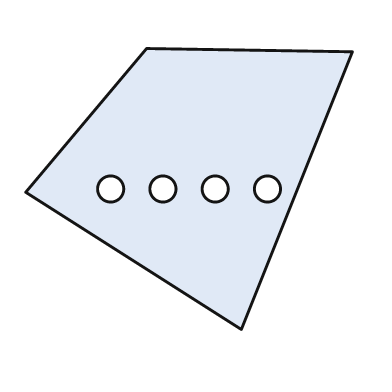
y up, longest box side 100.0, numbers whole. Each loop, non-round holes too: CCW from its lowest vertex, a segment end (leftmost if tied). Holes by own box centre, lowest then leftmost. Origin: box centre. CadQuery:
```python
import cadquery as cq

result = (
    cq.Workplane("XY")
    .moveTo(16.0, -43.0)
    .lineTo(50.0, 42.0)
    .lineTo(-13.0, 43.0)
    .lineTo(-50.0, -1.0)
    .close()
    .moveTo(-24.0, 0.0)
    .circle(4.0)
    .moveTo(-8.0, 0.0)
    .circle(4.0)
    .moveTo(8.0, 0.0)
    .circle(4.0)
    .moveTo(24.0, 0.0)
    .circle(4.0)
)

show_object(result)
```